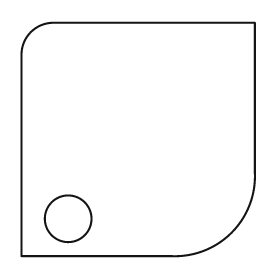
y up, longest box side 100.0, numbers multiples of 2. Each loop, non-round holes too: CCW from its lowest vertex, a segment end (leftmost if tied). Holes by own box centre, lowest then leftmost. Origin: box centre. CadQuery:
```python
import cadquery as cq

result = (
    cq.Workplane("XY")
    .moveTo(-50.0, -50.0)
    .lineTo(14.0, -50.0)
    .threePointArc((40.0, -40.0), (50.0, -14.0))
    .lineTo(50.0, 50.0)
    .lineTo(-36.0, 50.0)
    .threePointArc((-46.0, 46.0), (-50.0, 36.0))
    .close()
    .moveTo(-30.0, -34.0)
    .circle(10.0)
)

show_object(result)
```